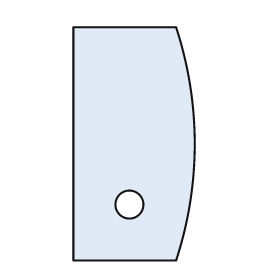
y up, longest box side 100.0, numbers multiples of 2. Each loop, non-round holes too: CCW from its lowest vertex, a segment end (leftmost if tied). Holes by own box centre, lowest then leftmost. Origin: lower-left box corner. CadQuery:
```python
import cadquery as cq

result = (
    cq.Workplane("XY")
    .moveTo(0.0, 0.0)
    .lineTo(44.0, 0.0)
    .threePointArc((52.0, 50.0), (44.0, 100.0))
    .lineTo(0.0, 100.0)
    .close()
    .moveTo(24.0, 24.0)
    .circle(6.0)
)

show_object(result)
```